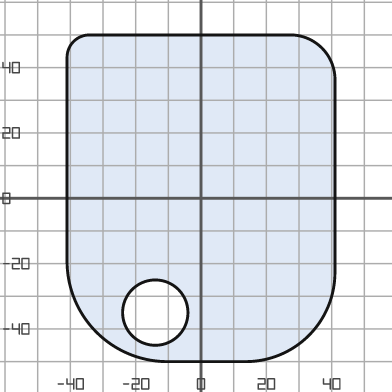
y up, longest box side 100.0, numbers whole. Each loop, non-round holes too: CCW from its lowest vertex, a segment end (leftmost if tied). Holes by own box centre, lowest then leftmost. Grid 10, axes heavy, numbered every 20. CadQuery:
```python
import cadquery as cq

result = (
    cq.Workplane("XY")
    .moveTo(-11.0, -50.0)
    .lineTo(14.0, -50.0)
    .threePointArc((33.0, -42.0), (41.0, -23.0))
    .lineTo(41.0, 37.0)
    .threePointArc((37.0, 46.0), (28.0, 50.0))
    .lineTo(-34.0, 50.0)
    .threePointArc((-39.0, 48.0), (-41.0, 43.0))
    .lineTo(-41.0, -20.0)
    .threePointArc((-32.0, -41.0), (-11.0, -50.0))
    .close()
    .moveTo(-14.0, -35.0)
    .circle(10.0)
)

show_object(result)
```